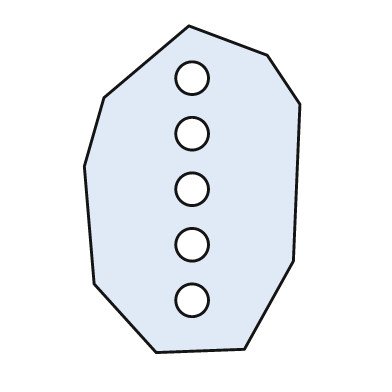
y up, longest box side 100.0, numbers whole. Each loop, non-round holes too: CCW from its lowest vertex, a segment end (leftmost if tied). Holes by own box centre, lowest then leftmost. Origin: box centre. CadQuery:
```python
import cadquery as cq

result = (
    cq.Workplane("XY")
    .moveTo(-11.0, -50.0)
    .lineTo(16.0, -49.0)
    .lineTo(31.0, -22.0)
    .lineTo(33.0, 26.0)
    .lineTo(23.0, 41.0)
    .lineTo(-1.0, 50.0)
    .lineTo(-27.0, 28.0)
    .lineTo(-33.0, 7.0)
    .lineTo(-30.0, -29.0)
    .close()
    .moveTo(0.0, -34.0)
    .circle(5.0)
    .moveTo(0.0, -17.0)
    .circle(5.0)
    .moveTo(0.0, 0.0)
    .circle(5.0)
    .moveTo(0.0, 17.0)
    .circle(5.0)
    .moveTo(0.0, 34.0)
    .circle(5.0)
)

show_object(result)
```